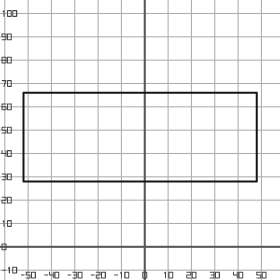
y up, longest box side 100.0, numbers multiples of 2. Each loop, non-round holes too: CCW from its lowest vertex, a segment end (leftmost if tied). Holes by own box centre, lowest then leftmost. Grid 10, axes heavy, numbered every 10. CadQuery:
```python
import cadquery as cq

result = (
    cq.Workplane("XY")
    .moveTo(-52.0, 28.0)
    .lineTo(48.0, 28.0)
    .lineTo(48.0, 66.0)
    .lineTo(-52.0, 66.0)
    .close()
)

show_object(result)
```